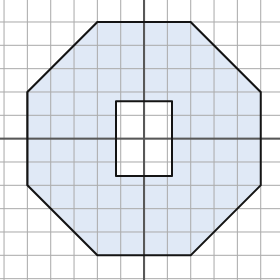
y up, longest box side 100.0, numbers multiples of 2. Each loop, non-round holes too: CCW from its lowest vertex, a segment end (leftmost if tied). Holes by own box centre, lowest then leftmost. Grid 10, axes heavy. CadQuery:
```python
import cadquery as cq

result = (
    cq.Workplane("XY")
    .moveTo(-20.0, -50.0)
    .lineTo(20.0, -50.0)
    .lineTo(50.0, -20.0)
    .lineTo(50.0, 20.0)
    .lineTo(20.0, 50.0)
    .lineTo(-20.0, 50.0)
    .lineTo(-50.0, 20.0)
    .lineTo(-50.0, -20.0)
    .close()
    .moveTo(-12.0, -16.0)
    .lineTo(12.0, -16.0)
    .lineTo(12.0, 16.0)
    .lineTo(-12.0, 16.0)
    .close()
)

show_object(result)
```